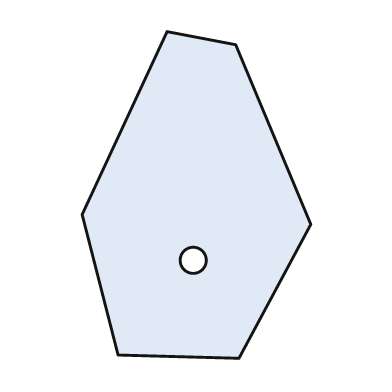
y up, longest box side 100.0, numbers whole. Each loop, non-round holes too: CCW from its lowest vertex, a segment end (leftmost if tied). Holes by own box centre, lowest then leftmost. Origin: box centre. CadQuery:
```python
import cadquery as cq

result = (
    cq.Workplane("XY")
    .moveTo(13.0, -50.0)
    .lineTo(35.0, -9.0)
    .lineTo(12.0, 46.0)
    .lineTo(-9.0, 50.0)
    .lineTo(-35.0, -6.0)
    .lineTo(-24.0, -49.0)
    .close()
    .moveTo(-1.0, -20.0)
    .circle(4.0)
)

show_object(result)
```